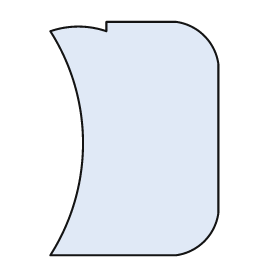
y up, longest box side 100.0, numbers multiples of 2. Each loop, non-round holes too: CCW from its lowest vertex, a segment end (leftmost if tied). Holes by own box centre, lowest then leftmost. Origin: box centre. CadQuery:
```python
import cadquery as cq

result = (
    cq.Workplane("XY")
    .moveTo(-36.0, -50.0)
    .lineTo(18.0, -50.0)
    .threePointArc((30.0, -44.0), (36.0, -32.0))
    .lineTo(36.0, 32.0)
    .threePointArc((30.0, 44.0), (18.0, 50.0))
    .lineTo(-12.0, 50.0)
    .lineTo(-12.0, 46.0)
    .threePointArc((-24.0, 48.0), (-36.0, 46.0))
    .threePointArc((-22.0, -2.0), (-36.0, -50.0))
    .close()
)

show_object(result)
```